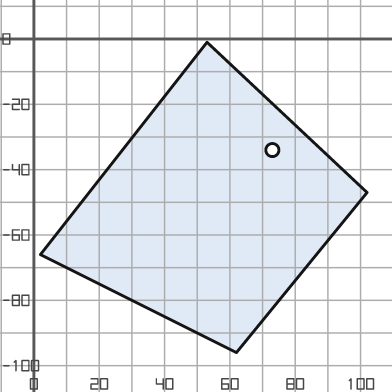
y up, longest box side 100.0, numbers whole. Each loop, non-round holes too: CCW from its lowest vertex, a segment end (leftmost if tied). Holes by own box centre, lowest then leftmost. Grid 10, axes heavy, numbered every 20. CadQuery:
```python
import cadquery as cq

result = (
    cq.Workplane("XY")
    .moveTo(62.0, -96.0)
    .lineTo(102.0, -47.0)
    .lineTo(53.0, -1.0)
    .lineTo(2.0, -66.0)
    .close()
    .moveTo(73.0, -34.0)
    .circle(2.0)
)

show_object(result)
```